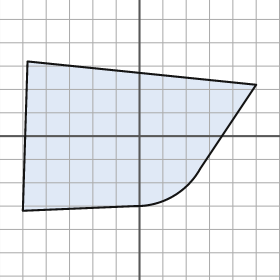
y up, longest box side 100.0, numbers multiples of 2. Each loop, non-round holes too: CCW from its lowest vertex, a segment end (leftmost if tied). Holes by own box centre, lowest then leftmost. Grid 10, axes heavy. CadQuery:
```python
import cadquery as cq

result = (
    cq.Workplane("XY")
    .moveTo(-50.0, -32.0)
    .lineTo(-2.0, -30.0)
    .threePointArc((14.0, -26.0), (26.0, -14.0))
    .lineTo(50.0, 22.0)
    .lineTo(-48.0, 32.0)
    .close()
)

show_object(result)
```